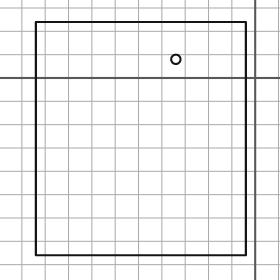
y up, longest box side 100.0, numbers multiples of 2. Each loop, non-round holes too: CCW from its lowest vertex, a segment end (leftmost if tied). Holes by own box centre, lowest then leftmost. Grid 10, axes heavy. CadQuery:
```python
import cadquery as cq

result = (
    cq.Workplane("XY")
    .moveTo(-94.0, -76.0)
    .lineTo(-4.0, -76.0)
    .lineTo(-4.0, 24.0)
    .lineTo(-94.0, 24.0)
    .close()
    .moveTo(-34.0, 8.0)
    .circle(2.0)
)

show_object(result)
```